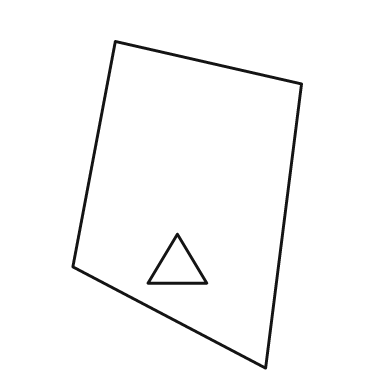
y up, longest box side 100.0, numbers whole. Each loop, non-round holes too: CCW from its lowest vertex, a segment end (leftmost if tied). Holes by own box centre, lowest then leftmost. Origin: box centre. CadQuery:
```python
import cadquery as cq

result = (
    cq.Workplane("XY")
    .moveTo(24.0, -50.0)
    .lineTo(35.0, 37.0)
    .lineTo(-22.0, 50.0)
    .lineTo(-35.0, -19.0)
    .close()
    .moveTo(-12.0, -24.0)
    .lineTo(6.0, -24.0)
    .lineTo(-3.0, -9.0)
    .close()
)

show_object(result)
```